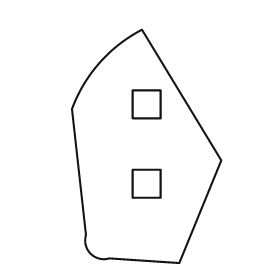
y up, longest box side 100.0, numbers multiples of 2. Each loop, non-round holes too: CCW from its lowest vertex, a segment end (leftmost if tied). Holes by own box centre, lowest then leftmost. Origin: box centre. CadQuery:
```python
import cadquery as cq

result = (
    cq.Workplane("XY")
    .moveTo(14.0, -50.0)
    .lineTo(32.0, -6.0)
    .lineTo(-2.0, 50.0)
    .threePointArc((-20.0, 36.0), (-32.0, 16.0))
    .lineTo(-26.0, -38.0)
    .threePointArc((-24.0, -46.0), (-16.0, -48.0))
    .close()
    .moveTo(-6.0, -22.0)
    .lineTo(6.0, -22.0)
    .lineTo(6.0, -10.0)
    .lineTo(-6.0, -10.0)
    .close()
    .moveTo(-6.0, 12.0)
    .lineTo(6.0, 12.0)
    .lineTo(6.0, 24.0)
    .lineTo(-6.0, 24.0)
    .close()
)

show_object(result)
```